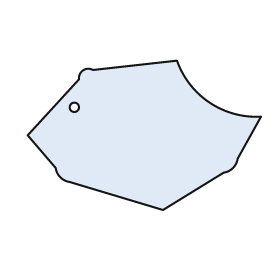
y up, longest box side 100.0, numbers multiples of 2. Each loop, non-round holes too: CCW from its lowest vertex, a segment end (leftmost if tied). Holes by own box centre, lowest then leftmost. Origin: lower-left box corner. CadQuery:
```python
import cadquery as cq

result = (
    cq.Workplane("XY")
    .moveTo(58.0, 0.0)
    .lineTo(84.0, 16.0)
    .threePointArc((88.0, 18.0), (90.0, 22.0))
    .lineTo(100.0, 40.0)
    .threePointArc((78.0, 46.0), (64.0, 64.0))
    .lineTo(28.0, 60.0)
    .threePointArc((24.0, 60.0), (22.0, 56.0))
    .lineTo(0.0, 32.0)
    .lineTo(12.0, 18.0)
    .threePointArc((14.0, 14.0), (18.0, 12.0))
    .close()
    .moveTo(20.0, 44.0)
    .circle(2.0)
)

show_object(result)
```